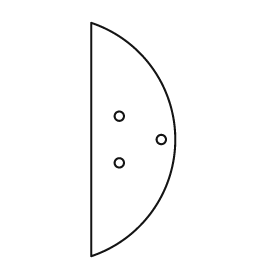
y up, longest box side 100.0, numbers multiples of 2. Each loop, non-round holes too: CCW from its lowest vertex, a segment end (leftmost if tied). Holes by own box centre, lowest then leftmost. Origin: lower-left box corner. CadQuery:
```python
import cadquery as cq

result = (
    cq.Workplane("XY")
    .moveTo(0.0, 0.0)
    .threePointArc((36.0, 50.0), (0.0, 100.0))
    .close()
    .moveTo(12.0, 40.0)
    .circle(2.0)
    .moveTo(30.0, 50.0)
    .circle(2.0)
    .moveTo(12.0, 60.0)
    .circle(2.0)
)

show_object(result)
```